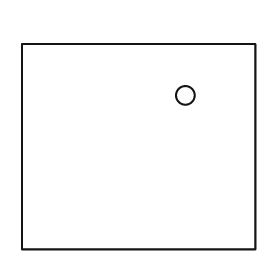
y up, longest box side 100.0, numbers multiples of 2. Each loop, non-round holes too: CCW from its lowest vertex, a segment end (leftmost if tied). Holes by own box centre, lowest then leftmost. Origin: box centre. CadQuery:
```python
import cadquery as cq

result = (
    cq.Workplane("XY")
    .moveTo(-50.0, -44.0)
    .lineTo(50.0, -44.0)
    .lineTo(50.0, 44.0)
    .lineTo(-50.0, 44.0)
    .close()
    .moveTo(20.0, 22.0)
    .circle(4.0)
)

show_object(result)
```